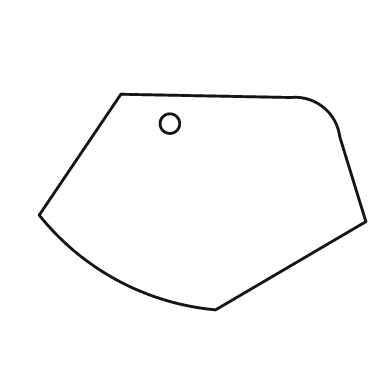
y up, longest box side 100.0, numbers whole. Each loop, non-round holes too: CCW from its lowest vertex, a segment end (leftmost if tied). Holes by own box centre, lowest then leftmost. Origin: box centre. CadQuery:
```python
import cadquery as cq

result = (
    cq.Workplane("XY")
    .moveTo(4.0, -33.0)
    .lineTo(50.0, -6.0)
    .lineTo(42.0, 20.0)
    .threePointArc((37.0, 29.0), (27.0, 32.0))
    .lineTo(-25.0, 33.0)
    .lineTo(-50.0, -4.0)
    .threePointArc((-26.0, -24.0), (4.0, -33.0))
    .close()
    .moveTo(-10.0, 24.0)
    .circle(3.0)
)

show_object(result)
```